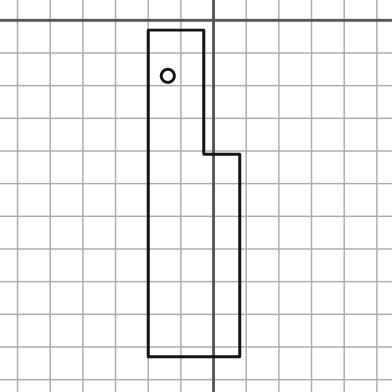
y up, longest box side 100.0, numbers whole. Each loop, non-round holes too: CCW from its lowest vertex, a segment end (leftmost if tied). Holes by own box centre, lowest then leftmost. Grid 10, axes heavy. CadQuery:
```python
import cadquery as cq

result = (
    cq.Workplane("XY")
    .moveTo(-20.0, -103.0)
    .lineTo(8.0, -103.0)
    .lineTo(8.0, -41.0)
    .lineTo(-3.0, -41.0)
    .lineTo(-3.0, -3.0)
    .lineTo(-20.0, -3.0)
    .close()
    .moveTo(-14.0, -17.0)
    .circle(2.0)
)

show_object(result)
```